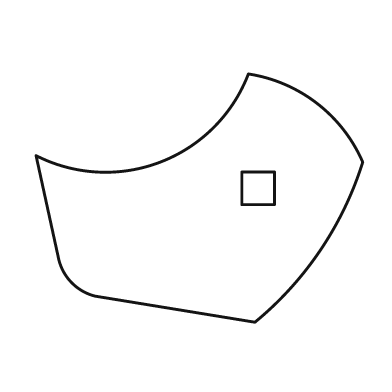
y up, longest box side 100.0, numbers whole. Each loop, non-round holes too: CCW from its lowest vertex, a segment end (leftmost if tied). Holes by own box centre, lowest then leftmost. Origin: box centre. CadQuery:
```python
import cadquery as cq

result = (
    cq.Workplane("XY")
    .moveTo(17.0, -38.0)
    .threePointArc((37.0, -16.0), (50.0, 11.0))
    .threePointArc((36.0, 29.0), (15.0, 38.0))
    .threePointArc((-12.0, 11.0), (-50.0, 13.0))
    .lineTo(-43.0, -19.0)
    .threePointArc((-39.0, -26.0), (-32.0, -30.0))
    .close()
    .moveTo(13.0, -2.0)
    .lineTo(23.0, -2.0)
    .lineTo(23.0, 8.0)
    .lineTo(13.0, 8.0)
    .close()
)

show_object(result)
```